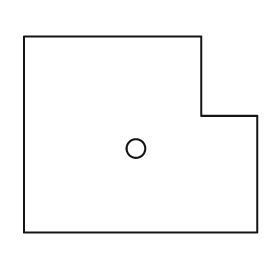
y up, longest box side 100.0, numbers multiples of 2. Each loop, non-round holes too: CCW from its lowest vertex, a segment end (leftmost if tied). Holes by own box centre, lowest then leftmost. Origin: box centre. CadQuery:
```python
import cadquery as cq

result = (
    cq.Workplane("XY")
    .moveTo(-50.0, -42.0)
    .lineTo(50.0, -42.0)
    .lineTo(50.0, 8.0)
    .lineTo(26.0, 8.0)
    .lineTo(26.0, 42.0)
    .lineTo(-50.0, 42.0)
    .close()
    .moveTo(-2.0, -6.0)
    .circle(4.0)
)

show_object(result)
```